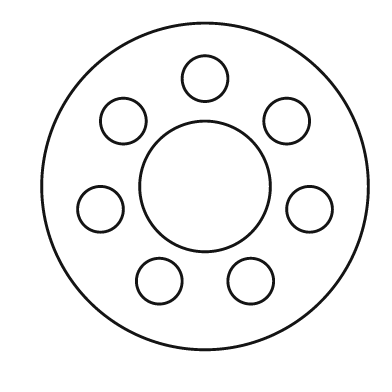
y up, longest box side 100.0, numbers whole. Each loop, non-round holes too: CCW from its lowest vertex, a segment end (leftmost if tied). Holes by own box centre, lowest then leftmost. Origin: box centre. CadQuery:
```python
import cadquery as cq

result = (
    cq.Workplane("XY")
    .moveTo(0.0, 0.0)
    .circle(50.0)
    .moveTo(-14.0, -29.0)
    .circle(7.0)
    .moveTo(14.0, -29.0)
    .circle(7.0)
    .moveTo(-32.0, -7.0)
    .circle(7.0)
    .moveTo(32.0, -7.0)
    .circle(7.0)
    .moveTo(0.0, 0.0)
    .circle(20.0)
    .moveTo(-25.0, 20.0)
    .circle(7.0)
    .moveTo(25.0, 20.0)
    .circle(7.0)
    .moveTo(0.0, 33.0)
    .circle(7.0)
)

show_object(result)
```